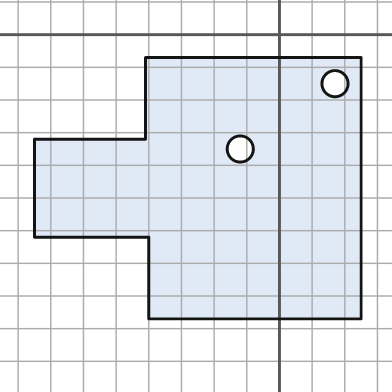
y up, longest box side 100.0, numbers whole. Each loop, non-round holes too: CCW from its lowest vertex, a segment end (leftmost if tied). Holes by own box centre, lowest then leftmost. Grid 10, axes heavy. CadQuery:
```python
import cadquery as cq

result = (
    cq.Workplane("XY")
    .moveTo(-40.0, -87.0)
    .lineTo(25.0, -87.0)
    .lineTo(25.0, -7.0)
    .lineTo(-41.0, -7.0)
    .lineTo(-41.0, -32.0)
    .lineTo(-75.0, -32.0)
    .lineTo(-75.0, -62.0)
    .lineTo(-40.0, -62.0)
    .close()
    .moveTo(-12.0, -35.0)
    .circle(4.0)
    .moveTo(17.0, -15.0)
    .circle(4.0)
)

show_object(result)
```